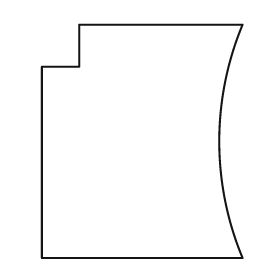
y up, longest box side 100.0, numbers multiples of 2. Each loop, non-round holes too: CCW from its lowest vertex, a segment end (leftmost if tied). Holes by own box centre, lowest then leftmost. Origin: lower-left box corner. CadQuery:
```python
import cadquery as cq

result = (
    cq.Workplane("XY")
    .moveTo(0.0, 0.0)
    .lineTo(86.0, 0.0)
    .threePointArc((76.0, 50.0), (86.0, 100.0))
    .lineTo(16.0, 100.0)
    .lineTo(16.0, 82.0)
    .lineTo(0.0, 82.0)
    .close()
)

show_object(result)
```